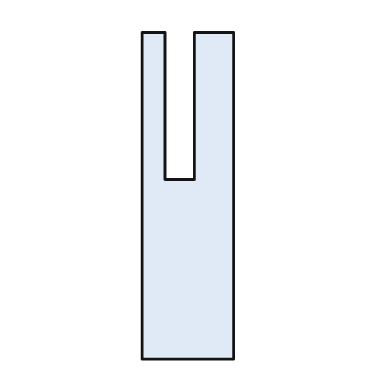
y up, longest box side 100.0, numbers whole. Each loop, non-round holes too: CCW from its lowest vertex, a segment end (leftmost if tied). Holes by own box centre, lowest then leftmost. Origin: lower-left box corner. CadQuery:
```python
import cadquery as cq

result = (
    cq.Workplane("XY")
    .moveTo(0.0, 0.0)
    .lineTo(28.0, 0.0)
    .lineTo(28.0, 100.0)
    .lineTo(16.0, 100.0)
    .lineTo(16.0, 55.0)
    .lineTo(7.0, 55.0)
    .lineTo(7.0, 100.0)
    .lineTo(0.0, 100.0)
    .close()
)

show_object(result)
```